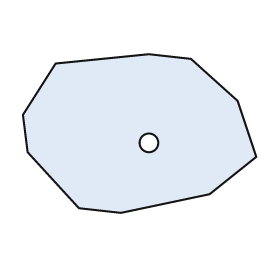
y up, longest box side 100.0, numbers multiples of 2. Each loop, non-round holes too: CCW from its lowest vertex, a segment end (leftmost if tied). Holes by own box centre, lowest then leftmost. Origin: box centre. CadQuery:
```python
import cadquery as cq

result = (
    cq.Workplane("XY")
    .moveTo(-8.0, -34.0)
    .lineTo(30.0, -26.0)
    .lineTo(50.0, -10.0)
    .lineTo(42.0, 14.0)
    .lineTo(22.0, 32.0)
    .lineTo(4.0, 34.0)
    .lineTo(-36.0, 30.0)
    .lineTo(-50.0, 8.0)
    .lineTo(-48.0, -8.0)
    .lineTo(-26.0, -32.0)
    .close()
    .moveTo(4.0, -4.0)
    .circle(4.0)
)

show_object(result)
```